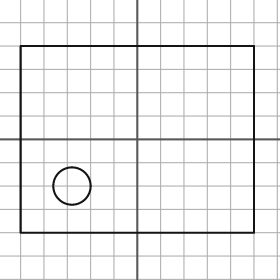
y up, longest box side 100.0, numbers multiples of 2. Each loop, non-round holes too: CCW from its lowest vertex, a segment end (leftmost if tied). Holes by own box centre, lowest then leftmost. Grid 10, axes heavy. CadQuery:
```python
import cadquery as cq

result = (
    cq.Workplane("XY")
    .moveTo(-50.0, -40.0)
    .lineTo(50.0, -40.0)
    .lineTo(50.0, 40.0)
    .lineTo(-50.0, 40.0)
    .close()
    .moveTo(-28.0, -20.0)
    .circle(8.0)
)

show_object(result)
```